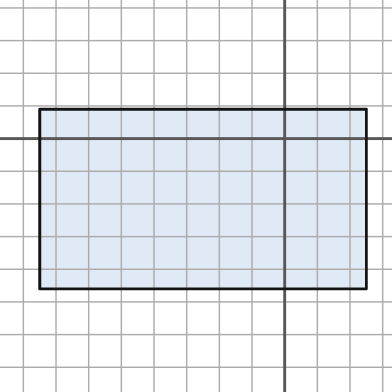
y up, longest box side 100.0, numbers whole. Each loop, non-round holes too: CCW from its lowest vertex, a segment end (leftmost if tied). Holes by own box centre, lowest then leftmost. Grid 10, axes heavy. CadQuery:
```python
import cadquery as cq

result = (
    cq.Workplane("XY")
    .moveTo(-75.0, -46.0)
    .lineTo(25.0, -46.0)
    .lineTo(25.0, 9.0)
    .lineTo(-75.0, 9.0)
    .close()
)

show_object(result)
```